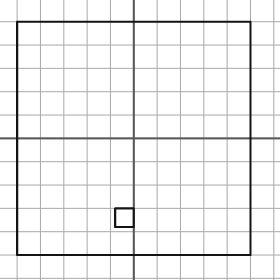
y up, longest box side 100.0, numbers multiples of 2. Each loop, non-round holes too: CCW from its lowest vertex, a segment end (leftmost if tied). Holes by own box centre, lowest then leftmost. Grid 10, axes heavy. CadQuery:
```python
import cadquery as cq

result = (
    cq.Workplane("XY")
    .moveTo(-50.0, -50.0)
    .lineTo(50.0, -50.0)
    .lineTo(50.0, 50.0)
    .lineTo(-50.0, 50.0)
    .close()
    .moveTo(-8.0, -38.0)
    .lineTo(0.0, -38.0)
    .lineTo(0.0, -30.0)
    .lineTo(-8.0, -30.0)
    .close()
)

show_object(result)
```